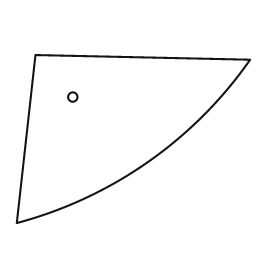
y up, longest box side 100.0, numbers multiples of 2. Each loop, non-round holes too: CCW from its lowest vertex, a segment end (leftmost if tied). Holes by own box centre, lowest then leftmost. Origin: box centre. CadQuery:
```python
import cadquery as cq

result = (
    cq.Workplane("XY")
    .moveTo(-50.0, -36.0)
    .threePointArc((6.0, -10.0), (50.0, 34.0))
    .lineTo(-42.0, 36.0)
    .close()
    .moveTo(-26.0, 18.0)
    .circle(2.0)
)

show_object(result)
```